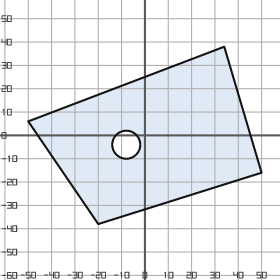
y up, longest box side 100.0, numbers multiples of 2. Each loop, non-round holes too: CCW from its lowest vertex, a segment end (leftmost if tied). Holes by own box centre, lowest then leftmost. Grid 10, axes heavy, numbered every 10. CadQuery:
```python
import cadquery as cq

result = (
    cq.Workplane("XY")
    .moveTo(-20.0, -38.0)
    .lineTo(50.0, -16.0)
    .lineTo(34.0, 38.0)
    .lineTo(-50.0, 6.0)
    .close()
    .moveTo(-8.0, -4.0)
    .circle(6.0)
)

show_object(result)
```